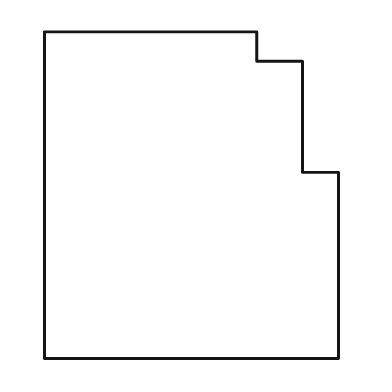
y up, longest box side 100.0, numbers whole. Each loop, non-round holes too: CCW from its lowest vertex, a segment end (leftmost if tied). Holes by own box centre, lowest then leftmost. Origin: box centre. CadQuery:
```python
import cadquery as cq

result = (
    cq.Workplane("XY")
    .moveTo(-45.0, -50.0)
    .lineTo(45.0, -50.0)
    .lineTo(45.0, 7.0)
    .lineTo(34.0, 7.0)
    .lineTo(34.0, 41.0)
    .lineTo(20.0, 41.0)
    .lineTo(20.0, 50.0)
    .lineTo(-45.0, 50.0)
    .close()
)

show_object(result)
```